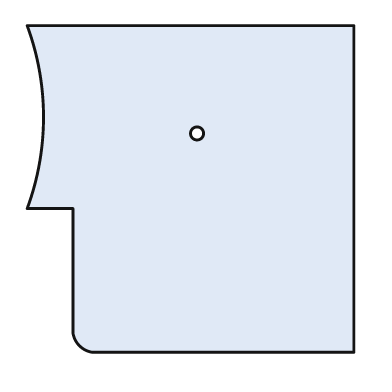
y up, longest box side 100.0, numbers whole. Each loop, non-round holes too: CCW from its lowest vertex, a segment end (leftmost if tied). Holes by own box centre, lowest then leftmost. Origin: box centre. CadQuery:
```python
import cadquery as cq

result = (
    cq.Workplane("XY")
    .moveTo(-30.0, -50.0)
    .lineTo(50.0, -50.0)
    .lineTo(50.0, 50.0)
    .lineTo(-50.0, 50.0)
    .threePointArc((-45.0, 22.0), (-50.0, -6.0))
    .lineTo(-36.0, -6.0)
    .lineTo(-36.0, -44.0)
    .threePointArc((-34.0, -48.0), (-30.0, -50.0))
    .close()
    .moveTo(2.0, 17.0)
    .circle(2.0)
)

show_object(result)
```